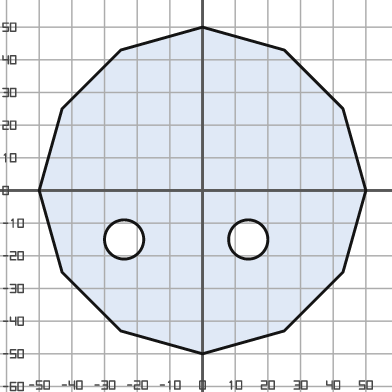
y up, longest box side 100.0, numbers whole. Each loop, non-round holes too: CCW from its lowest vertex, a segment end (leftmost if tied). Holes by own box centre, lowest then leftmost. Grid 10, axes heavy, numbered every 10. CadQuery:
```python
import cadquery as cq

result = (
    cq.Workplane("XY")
    .moveTo(0.0, -50.0)
    .lineTo(25.0, -43.0)
    .lineTo(43.0, -25.0)
    .lineTo(50.0, 0.0)
    .lineTo(43.0, 25.0)
    .lineTo(25.0, 43.0)
    .lineTo(0.0, 50.0)
    .lineTo(-25.0, 43.0)
    .lineTo(-43.0, 25.0)
    .lineTo(-50.0, 0.0)
    .lineTo(-43.0, -25.0)
    .lineTo(-25.0, -43.0)
    .close()
    .moveTo(-24.0, -15.0)
    .circle(6.0)
    .moveTo(14.0, -15.0)
    .circle(6.0)
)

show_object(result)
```